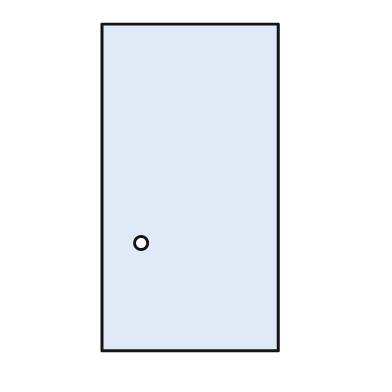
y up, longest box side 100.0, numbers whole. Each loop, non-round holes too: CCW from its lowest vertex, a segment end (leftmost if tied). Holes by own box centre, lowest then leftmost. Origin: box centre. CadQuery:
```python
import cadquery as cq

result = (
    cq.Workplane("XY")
    .moveTo(-27.0, -50.0)
    .lineTo(27.0, -50.0)
    .lineTo(27.0, 50.0)
    .lineTo(-27.0, 50.0)
    .close()
    .moveTo(-15.0, -17.0)
    .circle(2.0)
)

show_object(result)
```